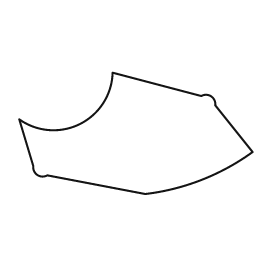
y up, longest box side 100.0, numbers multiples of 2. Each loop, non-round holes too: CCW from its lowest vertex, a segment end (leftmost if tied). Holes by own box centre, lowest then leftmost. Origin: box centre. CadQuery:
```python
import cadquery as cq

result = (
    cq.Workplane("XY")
    .moveTo(4.0, -26.0)
    .threePointArc((28.0, -20.0), (50.0, -8.0))
    .lineTo(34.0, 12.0)
    .threePointArc((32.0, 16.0), (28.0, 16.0))
    .lineTo(-10.0, 26.0)
    .threePointArc((-24.0, 4.0), (-50.0, 6.0))
    .lineTo(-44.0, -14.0)
    .threePointArc((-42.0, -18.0), (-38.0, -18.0))
    .close()
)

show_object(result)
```